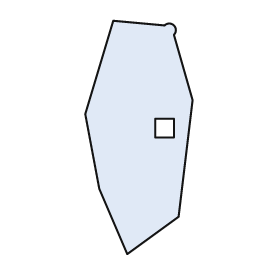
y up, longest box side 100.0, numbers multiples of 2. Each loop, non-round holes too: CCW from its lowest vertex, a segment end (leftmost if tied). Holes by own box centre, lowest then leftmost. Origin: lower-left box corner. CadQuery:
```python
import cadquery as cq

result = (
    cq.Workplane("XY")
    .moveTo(18.0, 0.0)
    .lineTo(40.0, 16.0)
    .lineTo(46.0, 66.0)
    .lineTo(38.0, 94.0)
    .threePointArc((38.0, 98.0), (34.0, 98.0))
    .lineTo(12.0, 100.0)
    .lineTo(0.0, 60.0)
    .lineTo(6.0, 28.0)
    .close()
    .moveTo(30.0, 50.0)
    .lineTo(38.0, 50.0)
    .lineTo(38.0, 58.0)
    .lineTo(30.0, 58.0)
    .close()
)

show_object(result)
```